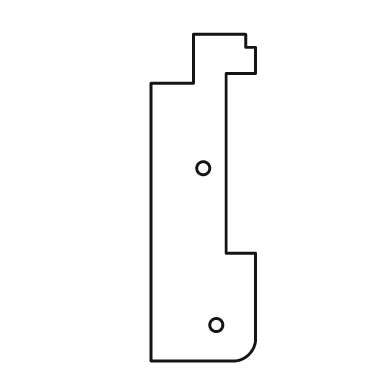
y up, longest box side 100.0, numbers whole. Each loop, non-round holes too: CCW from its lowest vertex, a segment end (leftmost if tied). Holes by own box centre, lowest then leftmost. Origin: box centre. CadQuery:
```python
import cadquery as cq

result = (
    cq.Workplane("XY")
    .moveTo(-16.0, -50.0)
    .lineTo(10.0, -50.0)
    .threePointArc((14.0, -48.0), (16.0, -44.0))
    .lineTo(16.0, -17.0)
    .lineTo(7.0, -17.0)
    .lineTo(7.0, 38.0)
    .lineTo(16.0, 38.0)
    .lineTo(16.0, 46.0)
    .lineTo(13.0, 46.0)
    .lineTo(13.0, 50.0)
    .lineTo(-3.0, 50.0)
    .lineTo(-3.0, 35.0)
    .lineTo(-16.0, 35.0)
    .close()
    .moveTo(4.0, -39.0)
    .circle(2.0)
    .moveTo(0.0, 9.0)
    .circle(2.0)
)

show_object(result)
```